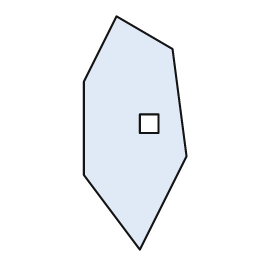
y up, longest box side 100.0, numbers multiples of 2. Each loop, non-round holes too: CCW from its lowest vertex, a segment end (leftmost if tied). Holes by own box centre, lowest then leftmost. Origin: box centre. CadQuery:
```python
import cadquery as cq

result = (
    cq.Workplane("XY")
    .moveTo(2.0, -50.0)
    .lineTo(22.0, -10.0)
    .lineTo(16.0, 36.0)
    .lineTo(-8.0, 50.0)
    .lineTo(-22.0, 22.0)
    .lineTo(-22.0, -18.0)
    .close()
    .moveTo(2.0, 0.0)
    .lineTo(10.0, 0.0)
    .lineTo(10.0, 8.0)
    .lineTo(2.0, 8.0)
    .close()
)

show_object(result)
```